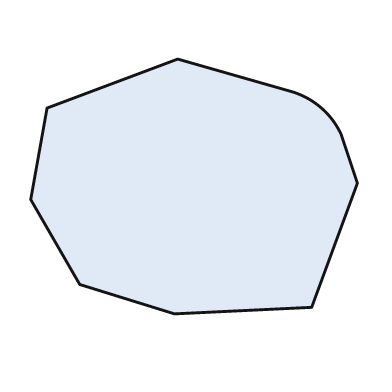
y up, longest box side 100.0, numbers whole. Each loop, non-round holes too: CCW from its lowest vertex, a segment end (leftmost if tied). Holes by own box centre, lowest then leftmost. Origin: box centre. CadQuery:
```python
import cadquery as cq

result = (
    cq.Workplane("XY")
    .moveTo(-6.0, -39.0)
    .lineTo(36.0, -37.0)
    .lineTo(50.0, 1.0)
    .lineTo(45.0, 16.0)
    .threePointArc((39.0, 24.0), (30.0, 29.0))
    .lineTo(-5.0, 39.0)
    .lineTo(-45.0, 24.0)
    .lineTo(-50.0, -4.0)
    .lineTo(-35.0, -30.0)
    .close()
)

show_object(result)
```